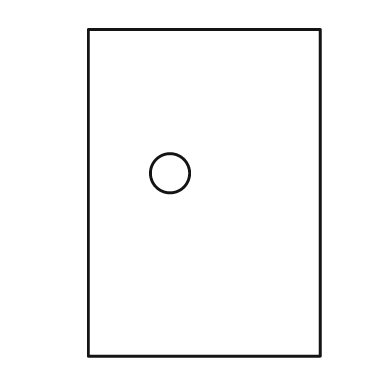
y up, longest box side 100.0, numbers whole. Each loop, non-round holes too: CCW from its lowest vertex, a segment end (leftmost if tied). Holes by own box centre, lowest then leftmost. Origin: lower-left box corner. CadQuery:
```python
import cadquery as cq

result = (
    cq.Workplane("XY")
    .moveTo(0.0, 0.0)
    .lineTo(71.0, 0.0)
    .lineTo(71.0, 100.0)
    .lineTo(0.0, 100.0)
    .close()
    .moveTo(25.0, 56.0)
    .circle(6.0)
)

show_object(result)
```